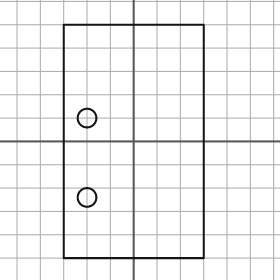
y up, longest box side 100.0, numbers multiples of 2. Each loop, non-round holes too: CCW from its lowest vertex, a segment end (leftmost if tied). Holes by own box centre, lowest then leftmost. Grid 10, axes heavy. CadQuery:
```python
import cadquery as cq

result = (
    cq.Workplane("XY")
    .moveTo(-30.0, -50.0)
    .lineTo(30.0, -50.0)
    .lineTo(30.0, 50.0)
    .lineTo(-30.0, 50.0)
    .close()
    .moveTo(-20.0, -24.0)
    .circle(4.0)
    .moveTo(-20.0, 10.0)
    .circle(4.0)
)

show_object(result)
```